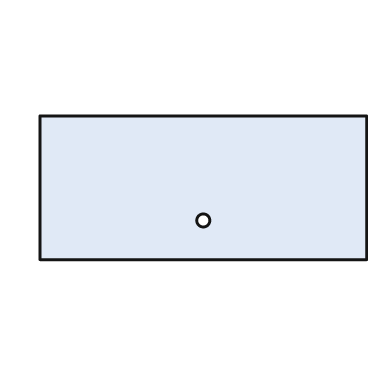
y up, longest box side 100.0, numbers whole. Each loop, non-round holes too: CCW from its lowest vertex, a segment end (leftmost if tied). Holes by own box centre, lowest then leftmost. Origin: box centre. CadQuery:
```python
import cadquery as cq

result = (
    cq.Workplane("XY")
    .moveTo(-50.0, -22.0)
    .lineTo(50.0, -22.0)
    .lineTo(50.0, 22.0)
    .lineTo(-50.0, 22.0)
    .close()
    .moveTo(0.0, -10.0)
    .circle(2.0)
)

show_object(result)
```